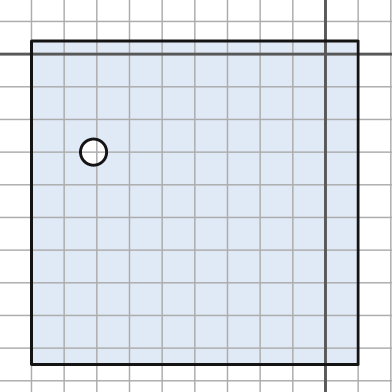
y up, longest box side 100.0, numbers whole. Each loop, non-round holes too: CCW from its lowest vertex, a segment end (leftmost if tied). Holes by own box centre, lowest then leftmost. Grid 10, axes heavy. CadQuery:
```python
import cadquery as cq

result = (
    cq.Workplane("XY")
    .moveTo(-90.0, -95.0)
    .lineTo(10.0, -95.0)
    .lineTo(10.0, 4.0)
    .lineTo(-90.0, 4.0)
    .close()
    .moveTo(-71.0, -30.0)
    .circle(4.0)
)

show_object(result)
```